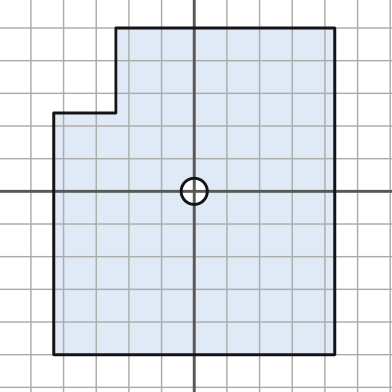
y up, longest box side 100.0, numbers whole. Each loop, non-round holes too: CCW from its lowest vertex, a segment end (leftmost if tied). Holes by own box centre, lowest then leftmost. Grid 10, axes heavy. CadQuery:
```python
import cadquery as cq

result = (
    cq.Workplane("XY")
    .moveTo(-43.0, -50.0)
    .lineTo(43.0, -50.0)
    .lineTo(43.0, 50.0)
    .lineTo(-24.0, 50.0)
    .lineTo(-24.0, 24.0)
    .lineTo(-43.0, 24.0)
    .close()
    .moveTo(0.0, 0.0)
    .circle(4.0)
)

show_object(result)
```